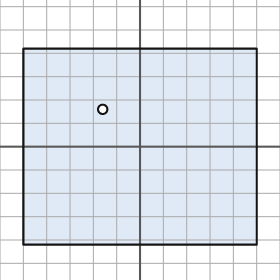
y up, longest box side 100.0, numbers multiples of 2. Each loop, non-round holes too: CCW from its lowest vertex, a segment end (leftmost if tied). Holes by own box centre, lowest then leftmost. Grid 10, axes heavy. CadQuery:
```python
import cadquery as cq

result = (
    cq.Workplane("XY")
    .moveTo(-50.0, -42.0)
    .lineTo(50.0, -42.0)
    .lineTo(50.0, 42.0)
    .lineTo(-50.0, 42.0)
    .close()
    .moveTo(-16.0, 16.0)
    .circle(2.0)
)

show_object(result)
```